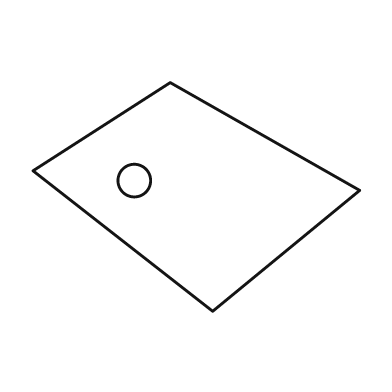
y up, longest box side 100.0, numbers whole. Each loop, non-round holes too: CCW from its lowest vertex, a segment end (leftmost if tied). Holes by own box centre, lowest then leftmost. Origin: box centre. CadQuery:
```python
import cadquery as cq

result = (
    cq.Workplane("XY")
    .moveTo(5.0, -35.0)
    .lineTo(50.0, 2.0)
    .lineTo(-8.0, 35.0)
    .lineTo(-50.0, 8.0)
    .close()
    .moveTo(-19.0, 5.0)
    .circle(5.0)
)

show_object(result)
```